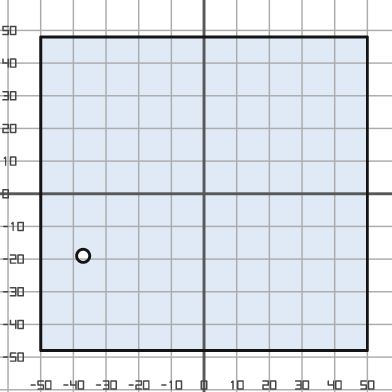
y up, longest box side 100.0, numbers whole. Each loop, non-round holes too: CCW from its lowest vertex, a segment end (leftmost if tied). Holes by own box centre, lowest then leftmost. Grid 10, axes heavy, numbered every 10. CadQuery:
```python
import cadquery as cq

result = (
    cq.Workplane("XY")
    .moveTo(-50.0, -48.0)
    .lineTo(50.0, -48.0)
    .lineTo(50.0, 48.0)
    .lineTo(-50.0, 48.0)
    .close()
    .moveTo(-37.0, -19.0)
    .circle(2.0)
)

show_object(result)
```